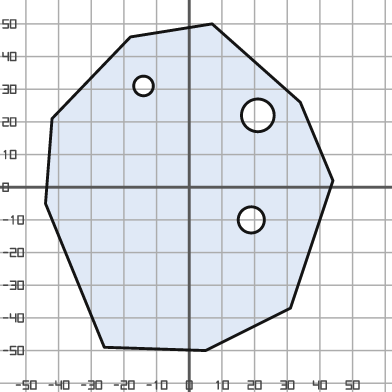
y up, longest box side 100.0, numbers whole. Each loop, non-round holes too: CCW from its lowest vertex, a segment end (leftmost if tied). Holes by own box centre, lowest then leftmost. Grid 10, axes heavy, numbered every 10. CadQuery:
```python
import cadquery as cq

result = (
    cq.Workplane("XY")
    .moveTo(5.0, -50.0)
    .lineTo(31.0, -37.0)
    .lineTo(44.0, 2.0)
    .lineTo(34.0, 26.0)
    .lineTo(7.0, 50.0)
    .lineTo(-18.0, 46.0)
    .lineTo(-42.0, 21.0)
    .lineTo(-44.0, -5.0)
    .lineTo(-26.0, -49.0)
    .close()
    .moveTo(19.0, -10.0)
    .circle(4.0)
    .moveTo(21.0, 22.0)
    .circle(5.0)
    .moveTo(-14.0, 31.0)
    .circle(3.0)
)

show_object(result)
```